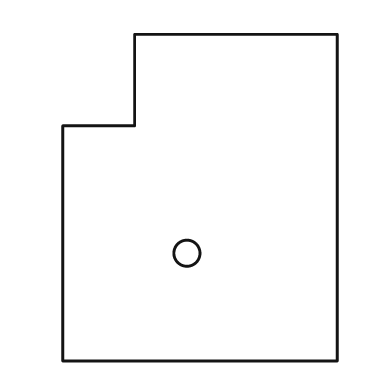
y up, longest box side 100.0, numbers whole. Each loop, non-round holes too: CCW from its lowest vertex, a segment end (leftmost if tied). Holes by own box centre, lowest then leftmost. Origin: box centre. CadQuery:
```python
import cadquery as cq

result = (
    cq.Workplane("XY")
    .moveTo(-42.0, -50.0)
    .lineTo(42.0, -50.0)
    .lineTo(42.0, 50.0)
    .lineTo(-20.0, 50.0)
    .lineTo(-20.0, 22.0)
    .lineTo(-42.0, 22.0)
    .close()
    .moveTo(-4.0, -17.0)
    .circle(4.0)
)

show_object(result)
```